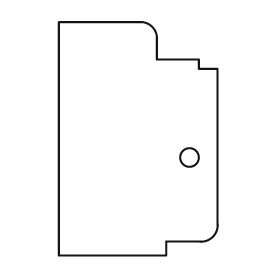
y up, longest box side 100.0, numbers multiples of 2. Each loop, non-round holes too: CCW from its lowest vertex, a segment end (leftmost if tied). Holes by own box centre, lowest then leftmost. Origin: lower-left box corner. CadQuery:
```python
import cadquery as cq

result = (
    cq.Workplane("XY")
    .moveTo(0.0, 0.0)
    .lineTo(46.0, 0.0)
    .lineTo(46.0, 6.0)
    .lineTo(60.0, 6.0)
    .threePointArc((66.0, 8.0), (68.0, 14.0))
    .lineTo(68.0, 80.0)
    .lineTo(60.0, 80.0)
    .lineTo(60.0, 84.0)
    .lineTo(42.0, 84.0)
    .lineTo(42.0, 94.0)
    .threePointArc((40.0, 98.0), (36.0, 100.0))
    .lineTo(0.0, 100.0)
    .close()
    .moveTo(56.0, 42.0)
    .circle(4.0)
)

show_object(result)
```